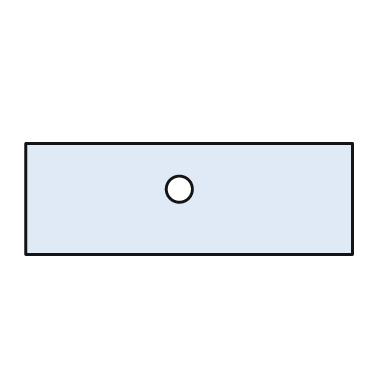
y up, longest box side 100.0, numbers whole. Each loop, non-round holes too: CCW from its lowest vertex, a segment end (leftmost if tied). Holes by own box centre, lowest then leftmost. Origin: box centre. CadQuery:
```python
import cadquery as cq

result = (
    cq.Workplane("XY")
    .moveTo(-50.0, -17.0)
    .lineTo(50.0, -17.0)
    .lineTo(50.0, 17.0)
    .lineTo(-50.0, 17.0)
    .close()
    .moveTo(-3.0, 3.0)
    .circle(4.0)
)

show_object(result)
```